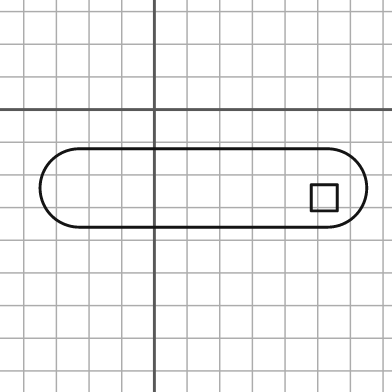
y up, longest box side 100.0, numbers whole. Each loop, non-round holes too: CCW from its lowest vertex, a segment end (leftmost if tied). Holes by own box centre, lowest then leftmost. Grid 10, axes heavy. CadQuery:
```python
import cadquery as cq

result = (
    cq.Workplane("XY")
    .moveTo(-23.0, -36.0)
    .lineTo(53.0, -36.0)
    .threePointArc((65.0, -24.0), (53.0, -12.0))
    .lineTo(-23.0, -12.0)
    .threePointArc((-35.0, -24.0), (-23.0, -36.0))
    .close()
    .moveTo(48.0, -31.0)
    .lineTo(56.0, -31.0)
    .lineTo(56.0, -23.0)
    .lineTo(48.0, -23.0)
    .close()
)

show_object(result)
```